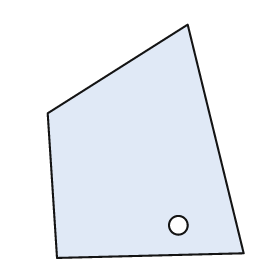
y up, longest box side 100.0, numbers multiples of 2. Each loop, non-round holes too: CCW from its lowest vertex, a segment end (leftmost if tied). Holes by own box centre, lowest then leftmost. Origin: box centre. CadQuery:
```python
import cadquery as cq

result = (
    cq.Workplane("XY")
    .moveTo(-38.0, -50.0)
    .lineTo(42.0, -48.0)
    .lineTo(18.0, 50.0)
    .lineTo(-42.0, 12.0)
    .close()
    .moveTo(14.0, -36.0)
    .circle(4.0)
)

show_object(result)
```